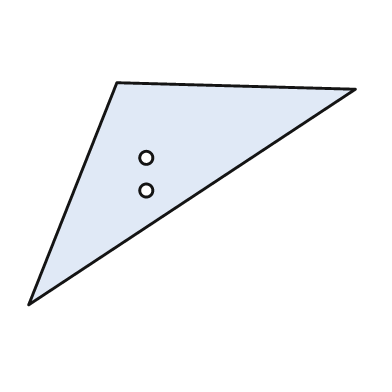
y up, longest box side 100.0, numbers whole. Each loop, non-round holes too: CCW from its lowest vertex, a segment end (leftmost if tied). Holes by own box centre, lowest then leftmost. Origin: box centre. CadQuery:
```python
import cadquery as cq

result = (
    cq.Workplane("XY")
    .moveTo(-50.0, -34.0)
    .lineTo(50.0, 32.0)
    .lineTo(-23.0, 34.0)
    .close()
    .moveTo(-14.0, 1.0)
    .circle(2.0)
    .moveTo(-14.0, 11.0)
    .circle(2.0)
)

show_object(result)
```